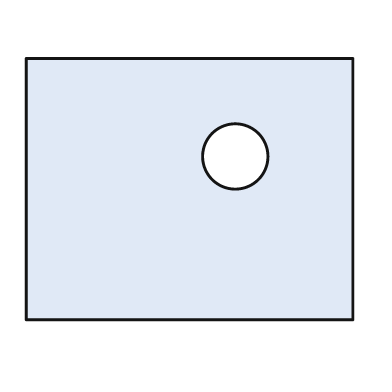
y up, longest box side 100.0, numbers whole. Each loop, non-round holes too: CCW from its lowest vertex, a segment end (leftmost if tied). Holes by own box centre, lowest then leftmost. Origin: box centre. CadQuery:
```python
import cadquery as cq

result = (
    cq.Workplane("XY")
    .moveTo(-50.0, -40.0)
    .lineTo(50.0, -40.0)
    .lineTo(50.0, 40.0)
    .lineTo(-50.0, 40.0)
    .close()
    .moveTo(14.0, 10.0)
    .circle(10.0)
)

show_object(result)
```